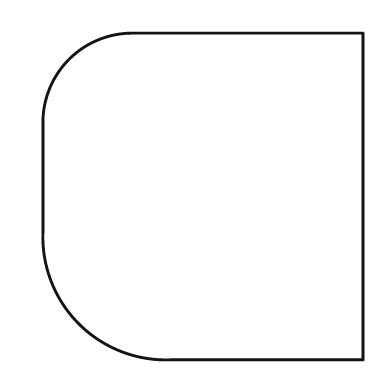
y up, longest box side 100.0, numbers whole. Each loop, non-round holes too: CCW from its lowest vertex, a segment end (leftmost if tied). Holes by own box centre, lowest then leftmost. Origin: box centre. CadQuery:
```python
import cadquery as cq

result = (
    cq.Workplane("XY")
    .moveTo(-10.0, -50.0)
    .lineTo(49.0, -50.0)
    .lineTo(49.0, 50.0)
    .lineTo(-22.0, 50.0)
    .threePointArc((-41.0, 42.0), (-49.0, 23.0))
    .lineTo(-49.0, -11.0)
    .threePointArc((-38.0, -39.0), (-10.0, -50.0))
    .close()
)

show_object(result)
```